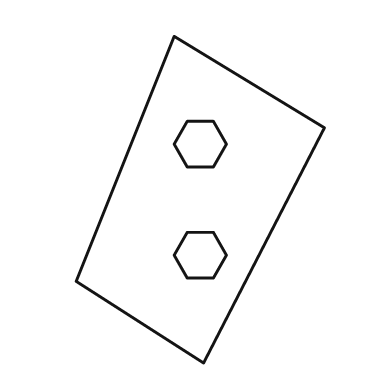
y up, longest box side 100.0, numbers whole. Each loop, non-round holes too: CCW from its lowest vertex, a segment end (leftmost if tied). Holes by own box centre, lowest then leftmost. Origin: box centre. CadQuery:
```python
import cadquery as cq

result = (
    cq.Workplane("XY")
    .moveTo(1.0, -50.0)
    .lineTo(38.0, 22.0)
    .lineTo(-8.0, 50.0)
    .lineTo(-38.0, -25.0)
    .close()
    .moveTo(-4.0, -24.0)
    .lineTo(4.0, -24.0)
    .lineTo(8.0, -17.0)
    .lineTo(4.0, -10.0)
    .lineTo(-4.0, -10.0)
    .lineTo(-8.0, -17.0)
    .close()
    .moveTo(-4.0, 10.0)
    .lineTo(4.0, 10.0)
    .lineTo(8.0, 17.0)
    .lineTo(4.0, 24.0)
    .lineTo(-4.0, 24.0)
    .lineTo(-8.0, 17.0)
    .close()
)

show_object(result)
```